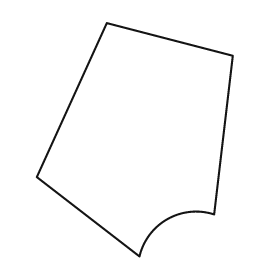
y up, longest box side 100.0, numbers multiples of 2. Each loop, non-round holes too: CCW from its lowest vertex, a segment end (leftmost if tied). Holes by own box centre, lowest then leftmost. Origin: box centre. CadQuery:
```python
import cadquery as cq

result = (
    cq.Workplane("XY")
    .moveTo(2.0, -50.0)
    .threePointArc((14.0, -34.0), (34.0, -32.0))
    .lineTo(42.0, 36.0)
    .lineTo(-12.0, 50.0)
    .lineTo(-42.0, -16.0)
    .close()
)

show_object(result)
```